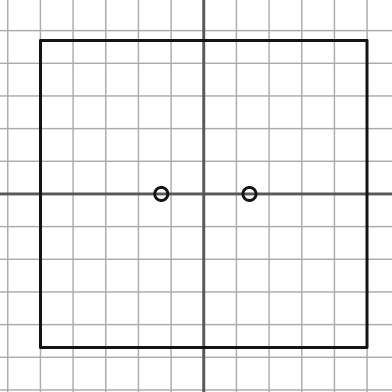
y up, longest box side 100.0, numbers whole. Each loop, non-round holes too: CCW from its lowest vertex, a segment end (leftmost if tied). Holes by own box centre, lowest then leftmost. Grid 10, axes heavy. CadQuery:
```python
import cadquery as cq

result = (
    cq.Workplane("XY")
    .moveTo(-50.0, -47.0)
    .lineTo(50.0, -47.0)
    .lineTo(50.0, 47.0)
    .lineTo(-50.0, 47.0)
    .close()
    .moveTo(-13.0, 0.0)
    .circle(2.0)
    .moveTo(14.0, 0.0)
    .circle(2.0)
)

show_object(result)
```